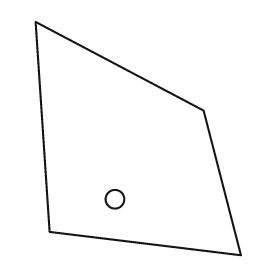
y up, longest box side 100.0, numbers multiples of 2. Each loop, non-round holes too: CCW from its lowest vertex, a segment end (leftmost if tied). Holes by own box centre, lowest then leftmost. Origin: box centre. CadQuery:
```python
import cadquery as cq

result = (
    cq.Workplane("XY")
    .moveTo(44.0, -50.0)
    .lineTo(28.0, 12.0)
    .lineTo(-44.0, 50.0)
    .lineTo(-38.0, -40.0)
    .close()
    .moveTo(-10.0, -26.0)
    .circle(4.0)
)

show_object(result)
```